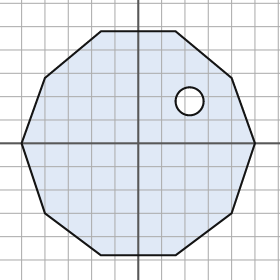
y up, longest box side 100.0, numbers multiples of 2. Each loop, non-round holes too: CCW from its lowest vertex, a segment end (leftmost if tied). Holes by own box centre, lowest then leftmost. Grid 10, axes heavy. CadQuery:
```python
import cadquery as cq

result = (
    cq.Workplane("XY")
    .moveTo(-16.0, -48.0)
    .lineTo(16.0, -48.0)
    .lineTo(40.0, -30.0)
    .lineTo(50.0, 0.0)
    .lineTo(40.0, 28.0)
    .lineTo(16.0, 48.0)
    .lineTo(-16.0, 48.0)
    .lineTo(-40.0, 28.0)
    .lineTo(-50.0, 0.0)
    .lineTo(-40.0, -30.0)
    .close()
    .moveTo(22.0, 18.0)
    .circle(6.0)
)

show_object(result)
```